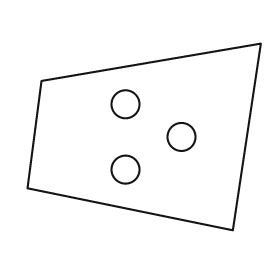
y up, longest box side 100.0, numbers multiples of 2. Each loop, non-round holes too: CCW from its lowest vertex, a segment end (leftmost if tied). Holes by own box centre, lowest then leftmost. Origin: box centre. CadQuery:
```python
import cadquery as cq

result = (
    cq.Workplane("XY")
    .moveTo(38.0, -40.0)
    .lineTo(50.0, 40.0)
    .lineTo(-44.0, 24.0)
    .lineTo(-50.0, -22.0)
    .close()
    .moveTo(-8.0, -14.0)
    .circle(6.0)
    .moveTo(16.0, 0.0)
    .circle(6.0)
    .moveTo(-8.0, 14.0)
    .circle(6.0)
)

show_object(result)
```